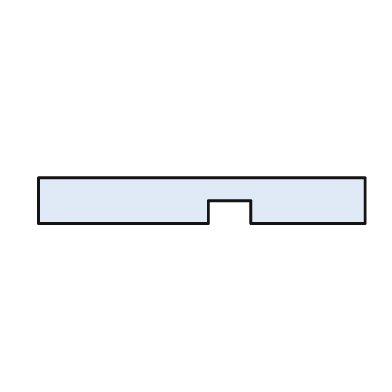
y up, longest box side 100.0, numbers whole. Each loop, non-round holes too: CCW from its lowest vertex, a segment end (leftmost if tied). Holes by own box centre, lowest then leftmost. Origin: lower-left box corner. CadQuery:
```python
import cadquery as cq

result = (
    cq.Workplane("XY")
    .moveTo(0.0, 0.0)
    .lineTo(52.0, 0.0)
    .lineTo(52.0, 7.0)
    .lineTo(65.0, 7.0)
    .lineTo(65.0, 0.0)
    .lineTo(100.0, 0.0)
    .lineTo(100.0, 14.0)
    .lineTo(0.0, 14.0)
    .close()
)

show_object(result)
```